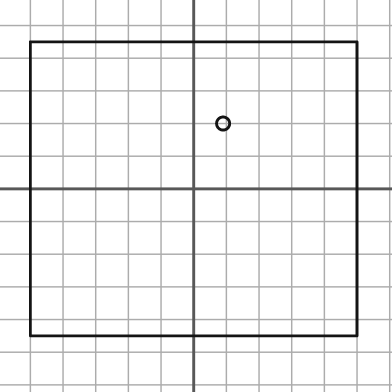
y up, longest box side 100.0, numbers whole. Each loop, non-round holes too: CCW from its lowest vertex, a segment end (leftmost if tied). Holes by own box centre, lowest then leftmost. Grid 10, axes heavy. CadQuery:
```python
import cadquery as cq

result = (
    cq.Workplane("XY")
    .moveTo(-50.0, -45.0)
    .lineTo(50.0, -45.0)
    .lineTo(50.0, 45.0)
    .lineTo(-50.0, 45.0)
    .close()
    .moveTo(9.0, 20.0)
    .circle(2.0)
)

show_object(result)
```